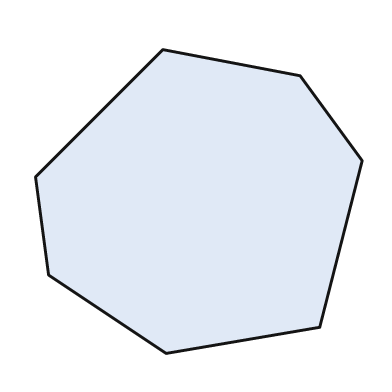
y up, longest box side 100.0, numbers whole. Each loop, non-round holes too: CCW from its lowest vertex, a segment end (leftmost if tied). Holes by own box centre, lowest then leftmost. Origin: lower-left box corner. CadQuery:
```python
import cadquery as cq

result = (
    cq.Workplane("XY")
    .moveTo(40.0, 0.0)
    .lineTo(87.0, 8.0)
    .lineTo(100.0, 59.0)
    .lineTo(81.0, 85.0)
    .lineTo(39.0, 93.0)
    .lineTo(0.0, 54.0)
    .lineTo(4.0, 24.0)
    .close()
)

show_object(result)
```